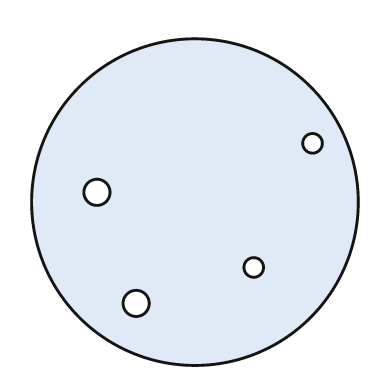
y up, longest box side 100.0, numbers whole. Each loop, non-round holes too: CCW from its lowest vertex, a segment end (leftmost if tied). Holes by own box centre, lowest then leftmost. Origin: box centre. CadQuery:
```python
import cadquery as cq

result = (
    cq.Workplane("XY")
    .moveTo(0.0, 0.0)
    .circle(50.0)
    .moveTo(-18.0, -31.0)
    .circle(4.0)
    .moveTo(18.0, -20.0)
    .circle(3.0)
    .moveTo(-30.0, 3.0)
    .circle(4.0)
    .moveTo(36.0, 18.0)
    .circle(3.0)
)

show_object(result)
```